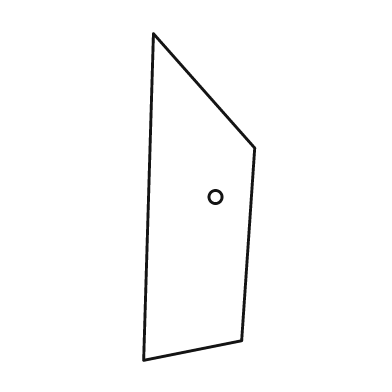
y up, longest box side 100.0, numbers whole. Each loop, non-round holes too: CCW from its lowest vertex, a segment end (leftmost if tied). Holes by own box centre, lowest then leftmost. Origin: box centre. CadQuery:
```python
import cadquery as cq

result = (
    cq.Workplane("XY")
    .moveTo(-17.0, -50.0)
    .lineTo(13.0, -44.0)
    .lineTo(17.0, 15.0)
    .lineTo(-14.0, 50.0)
    .close()
    .moveTo(5.0, 0.0)
    .circle(2.0)
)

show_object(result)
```